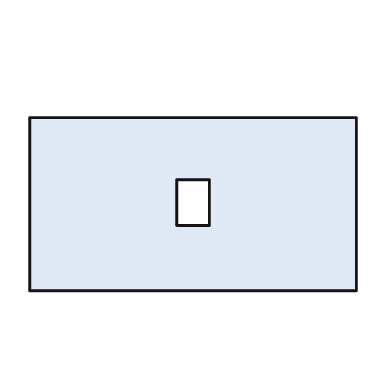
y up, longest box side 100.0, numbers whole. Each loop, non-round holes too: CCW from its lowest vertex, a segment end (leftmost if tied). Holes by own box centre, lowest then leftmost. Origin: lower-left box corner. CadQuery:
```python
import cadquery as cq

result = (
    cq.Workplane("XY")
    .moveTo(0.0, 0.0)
    .lineTo(100.0, 0.0)
    .lineTo(100.0, 53.0)
    .lineTo(0.0, 53.0)
    .close()
    .moveTo(45.0, 20.0)
    .lineTo(55.0, 20.0)
    .lineTo(55.0, 34.0)
    .lineTo(45.0, 34.0)
    .close()
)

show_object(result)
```